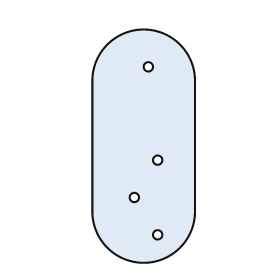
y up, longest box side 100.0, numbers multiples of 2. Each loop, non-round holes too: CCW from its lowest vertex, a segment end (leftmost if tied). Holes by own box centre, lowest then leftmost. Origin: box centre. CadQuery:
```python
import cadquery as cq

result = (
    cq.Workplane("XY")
    .moveTo(-22.0, -28.0)
    .threePointArc((0.0, -50.0), (22.0, -28.0))
    .lineTo(22.0, 28.0)
    .threePointArc((0.0, 50.0), (-22.0, 28.0))
    .close()
    .moveTo(6.0, -38.0)
    .circle(2.0)
    .moveTo(-4.0, -22.0)
    .circle(2.0)
    .moveTo(6.0, -6.0)
    .circle(2.0)
    .moveTo(2.0, 34.0)
    .circle(2.0)
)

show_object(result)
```